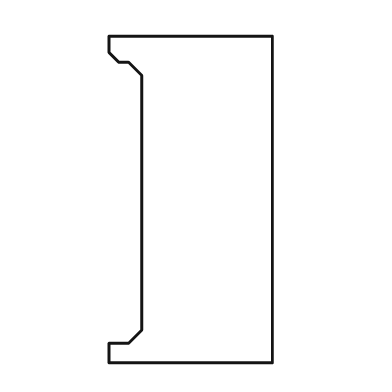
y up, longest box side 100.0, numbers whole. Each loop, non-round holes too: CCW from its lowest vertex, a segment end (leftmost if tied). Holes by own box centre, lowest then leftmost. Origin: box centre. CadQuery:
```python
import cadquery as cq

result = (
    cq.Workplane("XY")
    .moveTo(-25.0, -50.0)
    .lineTo(25.0, -50.0)
    .lineTo(25.0, 50.0)
    .lineTo(-25.0, 50.0)
    .lineTo(-25.0, 45.0)
    .lineTo(-22.0, 42.0)
    .lineTo(-19.0, 42.0)
    .lineTo(-15.0, 38.0)
    .lineTo(-15.0, -40.0)
    .lineTo(-19.0, -44.0)
    .lineTo(-25.0, -44.0)
    .close()
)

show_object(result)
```